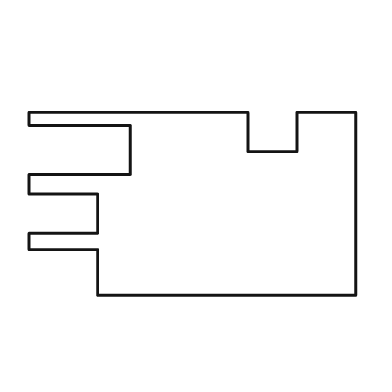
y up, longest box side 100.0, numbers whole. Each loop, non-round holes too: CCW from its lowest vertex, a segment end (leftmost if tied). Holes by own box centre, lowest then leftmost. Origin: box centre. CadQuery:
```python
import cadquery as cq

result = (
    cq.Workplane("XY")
    .moveTo(-29.0, -28.0)
    .lineTo(50.0, -28.0)
    .lineTo(50.0, 28.0)
    .lineTo(32.0, 28.0)
    .lineTo(32.0, 16.0)
    .lineTo(17.0, 16.0)
    .lineTo(17.0, 28.0)
    .lineTo(-50.0, 28.0)
    .lineTo(-50.0, 24.0)
    .lineTo(-19.0, 24.0)
    .lineTo(-19.0, 9.0)
    .lineTo(-50.0, 9.0)
    .lineTo(-50.0, 3.0)
    .lineTo(-29.0, 3.0)
    .lineTo(-29.0, -9.0)
    .lineTo(-50.0, -9.0)
    .lineTo(-50.0, -14.0)
    .lineTo(-29.0, -14.0)
    .close()
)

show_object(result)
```